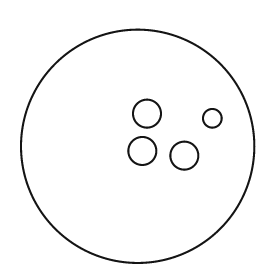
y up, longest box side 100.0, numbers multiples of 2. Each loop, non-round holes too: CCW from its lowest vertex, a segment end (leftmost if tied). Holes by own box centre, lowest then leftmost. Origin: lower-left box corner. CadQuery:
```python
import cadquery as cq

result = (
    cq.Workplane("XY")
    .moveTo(50.0, 50.0)
    .circle(50.0)
    .moveTo(70.0, 46.0)
    .circle(6.0)
    .moveTo(52.0, 48.0)
    .circle(6.0)
    .moveTo(82.0, 62.0)
    .circle(4.0)
    .moveTo(54.0, 64.0)
    .circle(6.0)
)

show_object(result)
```